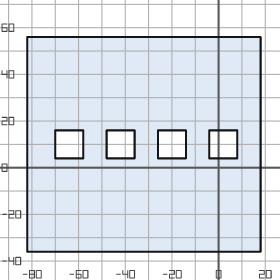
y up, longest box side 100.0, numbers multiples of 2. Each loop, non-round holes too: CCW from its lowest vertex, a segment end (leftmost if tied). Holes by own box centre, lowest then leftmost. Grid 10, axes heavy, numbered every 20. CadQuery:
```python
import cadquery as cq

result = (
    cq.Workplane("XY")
    .moveTo(-82.0, -36.0)
    .lineTo(18.0, -36.0)
    .lineTo(18.0, 56.0)
    .lineTo(-82.0, 56.0)
    .close()
    .moveTo(-70.0, 4.0)
    .lineTo(-58.0, 4.0)
    .lineTo(-58.0, 16.0)
    .lineTo(-70.0, 16.0)
    .close()
    .moveTo(-48.0, 4.0)
    .lineTo(-36.0, 4.0)
    .lineTo(-36.0, 16.0)
    .lineTo(-48.0, 16.0)
    .close()
    .moveTo(-26.0, 4.0)
    .lineTo(-14.0, 4.0)
    .lineTo(-14.0, 16.0)
    .lineTo(-26.0, 16.0)
    .close()
    .moveTo(-4.0, 4.0)
    .lineTo(8.0, 4.0)
    .lineTo(8.0, 16.0)
    .lineTo(-4.0, 16.0)
    .close()
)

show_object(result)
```